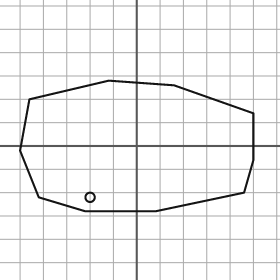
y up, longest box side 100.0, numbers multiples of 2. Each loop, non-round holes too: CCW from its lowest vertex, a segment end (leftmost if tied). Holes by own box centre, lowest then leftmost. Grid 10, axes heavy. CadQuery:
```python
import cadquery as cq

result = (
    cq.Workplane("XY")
    .moveTo(-22.0, -28.0)
    .lineTo(8.0, -28.0)
    .lineTo(46.0, -20.0)
    .lineTo(50.0, -6.0)
    .lineTo(50.0, 14.0)
    .lineTo(16.0, 26.0)
    .lineTo(-12.0, 28.0)
    .lineTo(-46.0, 20.0)
    .lineTo(-50.0, -2.0)
    .lineTo(-42.0, -22.0)
    .close()
    .moveTo(-20.0, -22.0)
    .circle(2.0)
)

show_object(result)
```